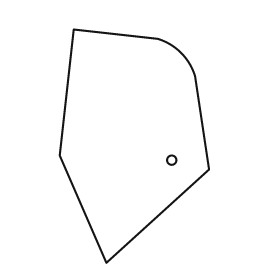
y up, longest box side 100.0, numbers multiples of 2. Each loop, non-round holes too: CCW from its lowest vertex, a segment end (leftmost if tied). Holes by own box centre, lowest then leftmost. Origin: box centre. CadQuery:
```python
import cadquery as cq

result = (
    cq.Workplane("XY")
    .moveTo(-12.0, -50.0)
    .lineTo(32.0, -10.0)
    .lineTo(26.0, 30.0)
    .threePointArc((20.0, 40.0), (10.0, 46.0))
    .lineTo(-26.0, 50.0)
    .lineTo(-32.0, -4.0)
    .close()
    .moveTo(16.0, -6.0)
    .circle(2.0)
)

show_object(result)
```